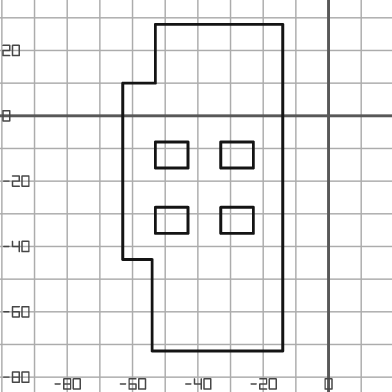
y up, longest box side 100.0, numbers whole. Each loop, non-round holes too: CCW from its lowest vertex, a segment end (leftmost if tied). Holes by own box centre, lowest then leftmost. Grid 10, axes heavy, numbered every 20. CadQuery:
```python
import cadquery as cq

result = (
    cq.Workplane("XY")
    .moveTo(-54.0, -72.0)
    .lineTo(-14.0, -72.0)
    .lineTo(-14.0, 28.0)
    .lineTo(-53.0, 28.0)
    .lineTo(-53.0, 10.0)
    .lineTo(-63.0, 10.0)
    .lineTo(-63.0, -44.0)
    .lineTo(-54.0, -44.0)
    .close()
    .moveTo(-53.0, -36.0)
    .lineTo(-43.0, -36.0)
    .lineTo(-43.0, -28.0)
    .lineTo(-53.0, -28.0)
    .close()
    .moveTo(-33.0, -36.0)
    .lineTo(-23.0, -36.0)
    .lineTo(-23.0, -28.0)
    .lineTo(-33.0, -28.0)
    .close()
    .moveTo(-53.0, -16.0)
    .lineTo(-43.0, -16.0)
    .lineTo(-43.0, -8.0)
    .lineTo(-53.0, -8.0)
    .close()
    .moveTo(-33.0, -16.0)
    .lineTo(-23.0, -16.0)
    .lineTo(-23.0, -8.0)
    .lineTo(-33.0, -8.0)
    .close()
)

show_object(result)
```